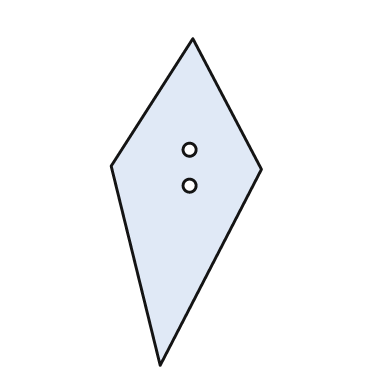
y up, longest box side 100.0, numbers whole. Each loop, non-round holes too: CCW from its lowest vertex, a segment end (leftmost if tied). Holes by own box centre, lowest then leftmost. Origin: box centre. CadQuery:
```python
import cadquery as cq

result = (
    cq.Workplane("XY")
    .moveTo(-8.0, -50.0)
    .lineTo(23.0, 10.0)
    .lineTo(2.0, 50.0)
    .lineTo(-23.0, 11.0)
    .close()
    .moveTo(1.0, 5.0)
    .circle(2.0)
    .moveTo(1.0, 16.0)
    .circle(2.0)
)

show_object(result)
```